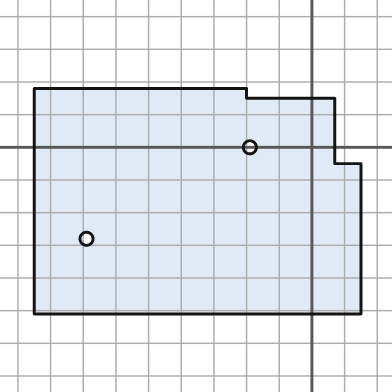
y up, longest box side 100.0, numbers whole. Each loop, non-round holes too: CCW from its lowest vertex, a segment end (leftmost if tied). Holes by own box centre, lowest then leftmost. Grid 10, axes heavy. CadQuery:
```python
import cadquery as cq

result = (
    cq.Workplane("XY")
    .moveTo(-85.0, -51.0)
    .lineTo(15.0, -51.0)
    .lineTo(15.0, -5.0)
    .lineTo(7.0, -5.0)
    .lineTo(7.0, 15.0)
    .lineTo(-20.0, 15.0)
    .lineTo(-20.0, 18.0)
    .lineTo(-85.0, 18.0)
    .close()
    .moveTo(-69.0, -28.0)
    .circle(2.0)
    .moveTo(-19.0, 0.0)
    .circle(2.0)
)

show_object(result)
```